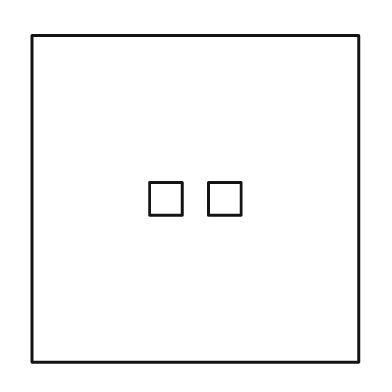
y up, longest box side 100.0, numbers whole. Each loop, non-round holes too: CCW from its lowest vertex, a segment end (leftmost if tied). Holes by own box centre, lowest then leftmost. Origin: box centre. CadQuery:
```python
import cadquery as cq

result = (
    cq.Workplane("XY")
    .moveTo(-50.0, -50.0)
    .lineTo(50.0, -50.0)
    .lineTo(50.0, 50.0)
    .lineTo(-50.0, 50.0)
    .close()
    .moveTo(-14.0, -5.0)
    .lineTo(-4.0, -5.0)
    .lineTo(-4.0, 5.0)
    .lineTo(-14.0, 5.0)
    .close()
    .moveTo(4.0, -5.0)
    .lineTo(14.0, -5.0)
    .lineTo(14.0, 5.0)
    .lineTo(4.0, 5.0)
    .close()
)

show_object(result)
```